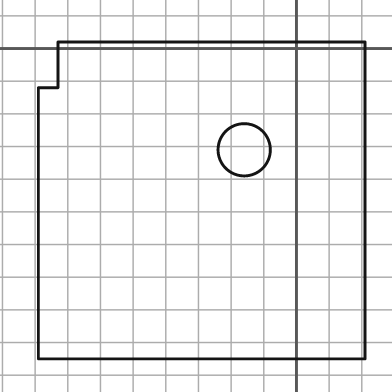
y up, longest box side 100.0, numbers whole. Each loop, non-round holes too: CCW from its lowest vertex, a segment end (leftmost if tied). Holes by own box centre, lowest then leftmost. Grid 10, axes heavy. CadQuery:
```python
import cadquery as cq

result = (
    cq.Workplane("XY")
    .moveTo(-79.0, -95.0)
    .lineTo(21.0, -95.0)
    .lineTo(21.0, 2.0)
    .lineTo(-73.0, 2.0)
    .lineTo(-73.0, -12.0)
    .lineTo(-79.0, -12.0)
    .close()
    .moveTo(-16.0, -31.0)
    .circle(8.0)
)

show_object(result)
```